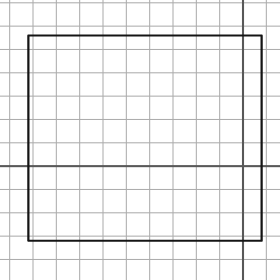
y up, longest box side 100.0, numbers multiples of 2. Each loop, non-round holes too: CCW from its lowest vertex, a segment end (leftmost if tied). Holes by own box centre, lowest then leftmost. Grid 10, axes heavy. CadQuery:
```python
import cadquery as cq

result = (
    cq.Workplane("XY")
    .moveTo(-92.0, -32.0)
    .lineTo(8.0, -32.0)
    .lineTo(8.0, 56.0)
    .lineTo(-92.0, 56.0)
    .close()
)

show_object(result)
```